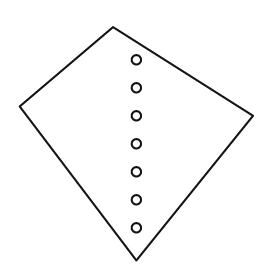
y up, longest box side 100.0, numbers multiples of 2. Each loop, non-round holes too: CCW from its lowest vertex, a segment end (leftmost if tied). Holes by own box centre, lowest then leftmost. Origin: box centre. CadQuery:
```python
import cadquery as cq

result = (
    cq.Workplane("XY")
    .moveTo(0.0, -50.0)
    .lineTo(50.0, 12.0)
    .lineTo(-10.0, 50.0)
    .lineTo(-50.0, 16.0)
    .close()
    .moveTo(0.0, -36.0)
    .circle(2.0)
    .moveTo(0.0, -24.0)
    .circle(2.0)
    .moveTo(0.0, -12.0)
    .circle(2.0)
    .moveTo(0.0, 0.0)
    .circle(2.0)
    .moveTo(0.0, 12.0)
    .circle(2.0)
    .moveTo(0.0, 24.0)
    .circle(2.0)
    .moveTo(0.0, 36.0)
    .circle(2.0)
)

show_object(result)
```